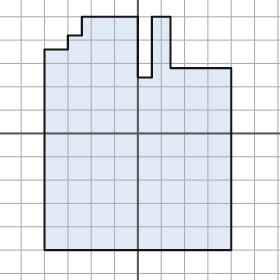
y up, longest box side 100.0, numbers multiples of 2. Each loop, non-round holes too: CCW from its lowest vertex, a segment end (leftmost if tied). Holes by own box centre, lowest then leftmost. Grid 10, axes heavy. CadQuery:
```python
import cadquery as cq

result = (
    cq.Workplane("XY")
    .moveTo(-40.0, -50.0)
    .lineTo(40.0, -50.0)
    .lineTo(40.0, 28.0)
    .lineTo(14.0, 28.0)
    .lineTo(14.0, 50.0)
    .lineTo(6.0, 50.0)
    .lineTo(6.0, 24.0)
    .lineTo(0.0, 24.0)
    .lineTo(0.0, 50.0)
    .lineTo(-24.0, 50.0)
    .lineTo(-24.0, 42.0)
    .lineTo(-30.0, 42.0)
    .lineTo(-30.0, 36.0)
    .lineTo(-40.0, 36.0)
    .close()
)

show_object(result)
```